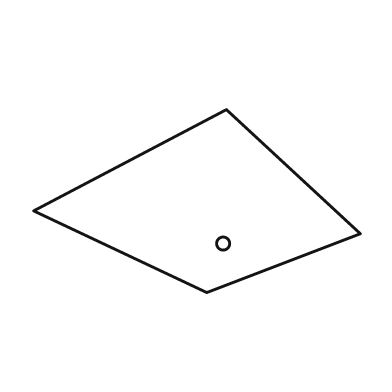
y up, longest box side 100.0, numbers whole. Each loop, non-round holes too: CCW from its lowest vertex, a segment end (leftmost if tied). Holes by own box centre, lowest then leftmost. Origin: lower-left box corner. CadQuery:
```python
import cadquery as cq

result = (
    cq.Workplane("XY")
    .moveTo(53.0, 0.0)
    .lineTo(100.0, 18.0)
    .lineTo(59.0, 56.0)
    .lineTo(0.0, 25.0)
    .close()
    .moveTo(58.0, 15.0)
    .circle(2.0)
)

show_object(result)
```